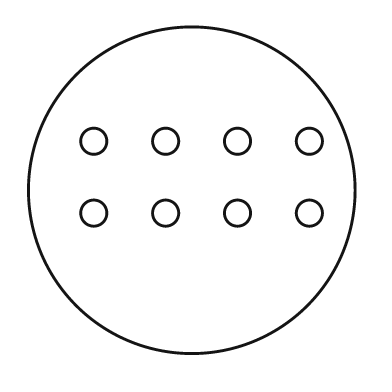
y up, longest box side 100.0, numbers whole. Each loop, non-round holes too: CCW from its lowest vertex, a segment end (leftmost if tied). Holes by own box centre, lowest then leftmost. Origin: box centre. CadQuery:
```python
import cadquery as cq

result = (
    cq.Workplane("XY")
    .moveTo(0.0, 0.0)
    .circle(50.0)
    .moveTo(-30.0, -7.0)
    .circle(4.0)
    .moveTo(-8.0, -7.0)
    .circle(4.0)
    .moveTo(14.0, -7.0)
    .circle(4.0)
    .moveTo(36.0, -7.0)
    .circle(4.0)
    .moveTo(-30.0, 15.0)
    .circle(4.0)
    .moveTo(-8.0, 15.0)
    .circle(4.0)
    .moveTo(14.0, 15.0)
    .circle(4.0)
    .moveTo(36.0, 15.0)
    .circle(4.0)
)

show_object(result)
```